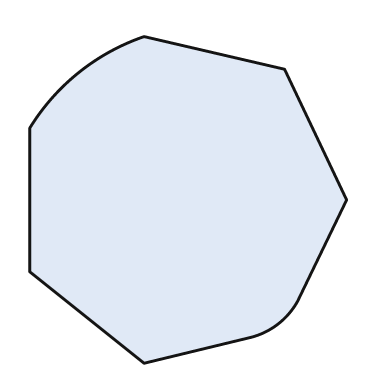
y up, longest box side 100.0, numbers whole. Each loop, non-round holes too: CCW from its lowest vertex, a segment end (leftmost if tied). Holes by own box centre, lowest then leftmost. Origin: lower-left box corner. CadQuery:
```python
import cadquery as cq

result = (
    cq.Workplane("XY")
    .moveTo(35.0, 0.0)
    .lineTo(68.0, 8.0)
    .threePointArc((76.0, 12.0), (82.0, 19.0))
    .lineTo(97.0, 50.0)
    .lineTo(78.0, 90.0)
    .lineTo(35.0, 100.0)
    .threePointArc((15.0, 89.0), (0.0, 72.0))
    .lineTo(0.0, 28.0)
    .close()
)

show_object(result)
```